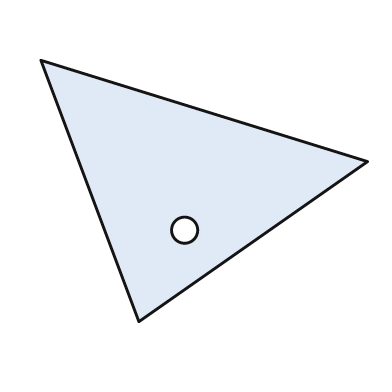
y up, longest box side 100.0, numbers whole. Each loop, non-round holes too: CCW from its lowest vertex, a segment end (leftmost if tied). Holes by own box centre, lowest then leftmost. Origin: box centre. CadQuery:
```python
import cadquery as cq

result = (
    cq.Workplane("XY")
    .moveTo(-20.0, -40.0)
    .lineTo(50.0, 9.0)
    .lineTo(-50.0, 40.0)
    .close()
    .moveTo(-6.0, -12.0)
    .circle(4.0)
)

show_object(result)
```